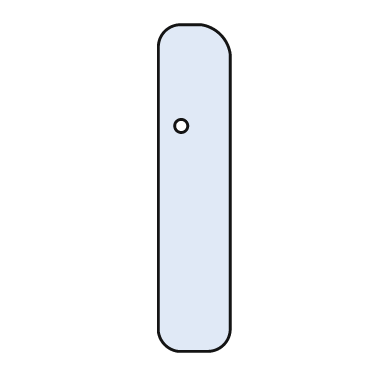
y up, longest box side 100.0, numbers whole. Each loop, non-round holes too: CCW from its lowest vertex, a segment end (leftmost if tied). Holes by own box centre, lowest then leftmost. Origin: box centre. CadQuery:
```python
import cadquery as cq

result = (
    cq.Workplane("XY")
    .moveTo(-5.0, -50.0)
    .lineTo(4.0, -50.0)
    .threePointArc((9.0, -48.0), (11.0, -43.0))
    .lineTo(11.0, 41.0)
    .threePointArc((8.0, 47.0), (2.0, 50.0))
    .lineTo(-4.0, 50.0)
    .threePointArc((-9.0, 48.0), (-11.0, 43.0))
    .lineTo(-11.0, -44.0)
    .threePointArc((-9.0, -48.0), (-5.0, -50.0))
    .close()
    .moveTo(-4.0, 19.0)
    .circle(2.0)
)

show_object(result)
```